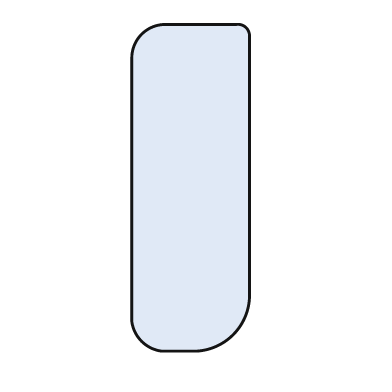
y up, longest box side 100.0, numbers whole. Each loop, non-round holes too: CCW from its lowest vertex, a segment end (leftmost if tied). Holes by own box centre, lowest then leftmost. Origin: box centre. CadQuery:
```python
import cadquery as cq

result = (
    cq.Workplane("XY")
    .moveTo(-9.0, -50.0)
    .lineTo(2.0, -50.0)
    .threePointArc((13.0, -45.0), (18.0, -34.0))
    .lineTo(18.0, 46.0)
    .threePointArc((17.0, 49.0), (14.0, 50.0))
    .lineTo(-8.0, 50.0)
    .threePointArc((-15.0, 47.0), (-18.0, 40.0))
    .lineTo(-18.0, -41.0)
    .threePointArc((-15.0, -47.0), (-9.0, -50.0))
    .close()
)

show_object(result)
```